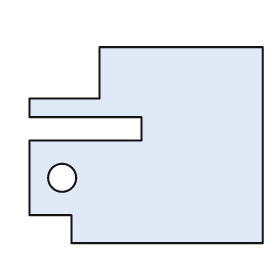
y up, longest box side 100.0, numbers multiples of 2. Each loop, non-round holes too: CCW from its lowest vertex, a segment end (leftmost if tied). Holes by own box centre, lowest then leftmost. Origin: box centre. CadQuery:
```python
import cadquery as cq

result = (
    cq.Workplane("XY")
    .moveTo(-32.0, -42.0)
    .lineTo(50.0, -42.0)
    .lineTo(50.0, 42.0)
    .lineTo(-20.0, 42.0)
    .lineTo(-20.0, 20.0)
    .lineTo(-50.0, 20.0)
    .lineTo(-50.0, 12.0)
    .lineTo(-2.0, 12.0)
    .lineTo(-2.0, 2.0)
    .lineTo(-50.0, 2.0)
    .lineTo(-50.0, -30.0)
    .lineTo(-32.0, -30.0)
    .close()
    .moveTo(-36.0, -14.0)
    .circle(6.0)
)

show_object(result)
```